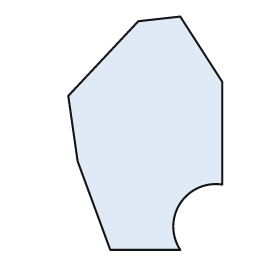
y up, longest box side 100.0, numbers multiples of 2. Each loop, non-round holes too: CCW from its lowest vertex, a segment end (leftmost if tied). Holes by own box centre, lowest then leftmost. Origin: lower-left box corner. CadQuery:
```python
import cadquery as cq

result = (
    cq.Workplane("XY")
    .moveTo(18.0, 0.0)
    .lineTo(48.0, 0.0)
    .threePointArc((48.0, 20.0), (66.0, 28.0))
    .lineTo(66.0, 72.0)
    .lineTo(48.0, 100.0)
    .lineTo(30.0, 98.0)
    .lineTo(0.0, 66.0)
    .lineTo(4.0, 38.0)
    .close()
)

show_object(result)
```